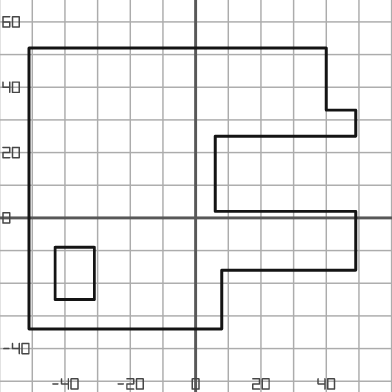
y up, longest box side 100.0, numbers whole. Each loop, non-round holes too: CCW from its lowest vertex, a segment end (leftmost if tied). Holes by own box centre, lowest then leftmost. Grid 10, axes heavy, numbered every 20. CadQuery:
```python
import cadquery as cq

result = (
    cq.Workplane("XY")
    .moveTo(-51.0, -34.0)
    .lineTo(8.0, -34.0)
    .lineTo(8.0, -16.0)
    .lineTo(49.0, -16.0)
    .lineTo(49.0, 2.0)
    .lineTo(6.0, 2.0)
    .lineTo(6.0, 25.0)
    .lineTo(49.0, 25.0)
    .lineTo(49.0, 33.0)
    .lineTo(40.0, 33.0)
    .lineTo(40.0, 52.0)
    .lineTo(-51.0, 52.0)
    .close()
    .moveTo(-43.0, -25.0)
    .lineTo(-31.0, -25.0)
    .lineTo(-31.0, -9.0)
    .lineTo(-43.0, -9.0)
    .close()
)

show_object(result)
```